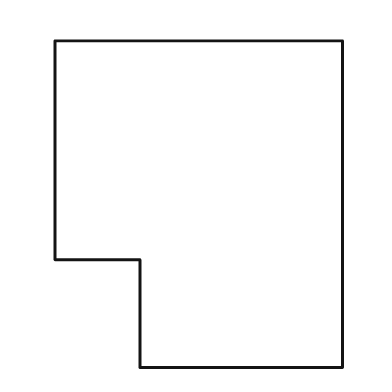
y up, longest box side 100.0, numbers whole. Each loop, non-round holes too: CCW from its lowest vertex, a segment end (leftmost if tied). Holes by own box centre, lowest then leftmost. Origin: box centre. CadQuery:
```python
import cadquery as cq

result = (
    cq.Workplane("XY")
    .moveTo(-18.0, -50.0)
    .lineTo(44.0, -50.0)
    .lineTo(44.0, 50.0)
    .lineTo(-44.0, 50.0)
    .lineTo(-44.0, -17.0)
    .lineTo(-18.0, -17.0)
    .close()
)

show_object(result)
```